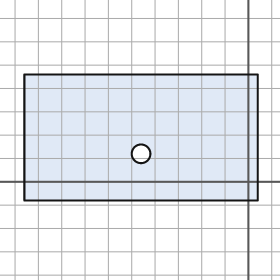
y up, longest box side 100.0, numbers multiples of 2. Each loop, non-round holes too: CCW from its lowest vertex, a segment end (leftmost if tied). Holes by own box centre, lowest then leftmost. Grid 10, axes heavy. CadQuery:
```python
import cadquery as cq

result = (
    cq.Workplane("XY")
    .moveTo(-96.0, -8.0)
    .lineTo(4.0, -8.0)
    .lineTo(4.0, 46.0)
    .lineTo(-96.0, 46.0)
    .close()
    .moveTo(-46.0, 12.0)
    .circle(4.0)
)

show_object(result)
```